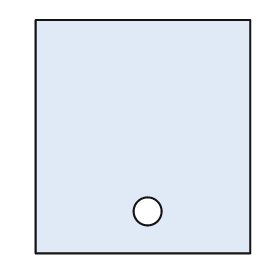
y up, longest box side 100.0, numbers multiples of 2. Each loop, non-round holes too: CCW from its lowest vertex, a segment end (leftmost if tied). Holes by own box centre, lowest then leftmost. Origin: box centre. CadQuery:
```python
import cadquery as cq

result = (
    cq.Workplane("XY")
    .moveTo(-46.0, -50.0)
    .lineTo(46.0, -50.0)
    .lineTo(46.0, 50.0)
    .lineTo(-46.0, 50.0)
    .close()
    .moveTo(2.0, -32.0)
    .circle(6.0)
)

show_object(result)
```